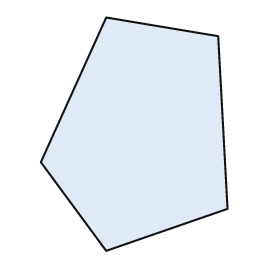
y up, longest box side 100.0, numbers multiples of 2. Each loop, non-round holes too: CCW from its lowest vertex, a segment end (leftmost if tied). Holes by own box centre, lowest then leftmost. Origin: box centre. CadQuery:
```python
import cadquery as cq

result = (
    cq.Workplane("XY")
    .moveTo(-12.0, -50.0)
    .lineTo(40.0, -32.0)
    .lineTo(36.0, 42.0)
    .lineTo(-12.0, 50.0)
    .lineTo(-40.0, -12.0)
    .close()
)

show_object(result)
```